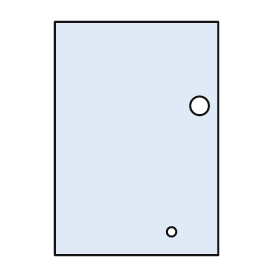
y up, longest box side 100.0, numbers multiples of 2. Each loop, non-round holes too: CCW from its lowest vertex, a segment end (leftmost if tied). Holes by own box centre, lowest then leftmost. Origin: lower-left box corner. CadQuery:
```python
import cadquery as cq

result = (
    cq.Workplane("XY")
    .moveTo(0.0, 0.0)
    .lineTo(70.0, 0.0)
    .lineTo(70.0, 100.0)
    .lineTo(0.0, 100.0)
    .close()
    .moveTo(50.0, 10.0)
    .circle(2.0)
    .moveTo(62.0, 64.0)
    .circle(4.0)
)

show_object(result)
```